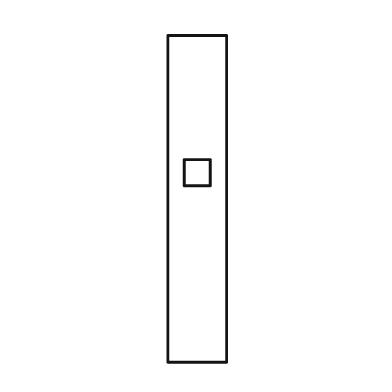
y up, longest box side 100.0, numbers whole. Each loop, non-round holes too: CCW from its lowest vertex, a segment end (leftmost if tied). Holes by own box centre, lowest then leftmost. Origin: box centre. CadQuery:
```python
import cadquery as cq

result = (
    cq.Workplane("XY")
    .moveTo(-9.0, -50.0)
    .lineTo(9.0, -50.0)
    .lineTo(9.0, 50.0)
    .lineTo(-9.0, 50.0)
    .close()
    .moveTo(-4.0, 4.0)
    .lineTo(4.0, 4.0)
    .lineTo(4.0, 12.0)
    .lineTo(-4.0, 12.0)
    .close()
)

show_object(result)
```